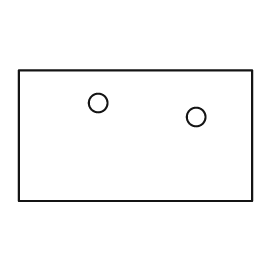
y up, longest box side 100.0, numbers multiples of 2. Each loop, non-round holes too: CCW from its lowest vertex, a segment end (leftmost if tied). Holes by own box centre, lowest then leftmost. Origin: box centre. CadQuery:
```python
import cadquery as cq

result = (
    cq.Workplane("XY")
    .moveTo(-50.0, -28.0)
    .lineTo(50.0, -28.0)
    .lineTo(50.0, 28.0)
    .lineTo(-50.0, 28.0)
    .close()
    .moveTo(26.0, 8.0)
    .circle(4.0)
    .moveTo(-16.0, 14.0)
    .circle(4.0)
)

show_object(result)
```